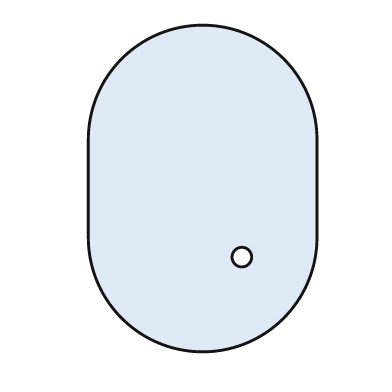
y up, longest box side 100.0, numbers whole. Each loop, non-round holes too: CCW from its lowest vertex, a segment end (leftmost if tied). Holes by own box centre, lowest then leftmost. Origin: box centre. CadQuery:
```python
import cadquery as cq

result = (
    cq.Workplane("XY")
    .moveTo(-35.0, -15.0)
    .threePointArc((0.0, -50.0), (35.0, -15.0))
    .lineTo(35.0, 15.0)
    .threePointArc((0.0, 50.0), (-35.0, 15.0))
    .close()
    .moveTo(12.0, -21.0)
    .circle(3.0)
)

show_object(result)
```